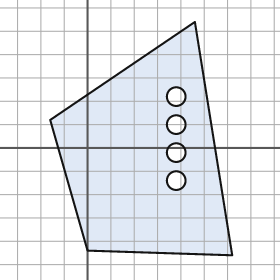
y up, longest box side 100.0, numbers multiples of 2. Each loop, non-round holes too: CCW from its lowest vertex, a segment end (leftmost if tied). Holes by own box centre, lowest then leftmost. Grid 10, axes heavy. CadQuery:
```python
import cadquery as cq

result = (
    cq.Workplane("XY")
    .moveTo(62.0, -46.0)
    .lineTo(46.0, 54.0)
    .lineTo(-16.0, 12.0)
    .lineTo(0.0, -44.0)
    .close()
    .moveTo(38.0, -14.0)
    .circle(4.0)
    .moveTo(38.0, -2.0)
    .circle(4.0)
    .moveTo(38.0, 10.0)
    .circle(4.0)
    .moveTo(38.0, 22.0)
    .circle(4.0)
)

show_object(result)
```